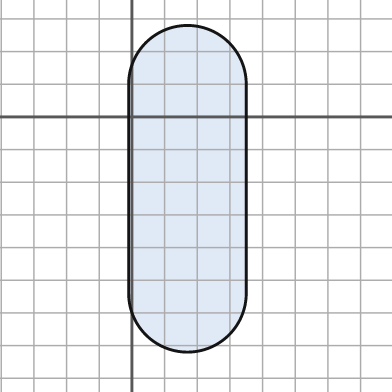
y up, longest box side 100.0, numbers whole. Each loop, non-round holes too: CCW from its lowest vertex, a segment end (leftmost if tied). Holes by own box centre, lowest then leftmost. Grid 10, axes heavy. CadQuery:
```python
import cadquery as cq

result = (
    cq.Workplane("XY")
    .moveTo(-1.0, -54.0)
    .threePointArc((17.0, -72.0), (35.0, -54.0))
    .lineTo(35.0, 10.0)
    .threePointArc((17.0, 28.0), (-1.0, 10.0))
    .close()
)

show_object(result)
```